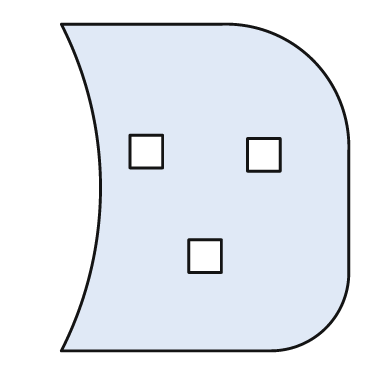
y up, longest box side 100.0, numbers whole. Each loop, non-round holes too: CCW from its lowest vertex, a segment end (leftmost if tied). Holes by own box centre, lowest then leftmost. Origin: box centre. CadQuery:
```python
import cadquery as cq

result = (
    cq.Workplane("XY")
    .moveTo(-44.0, -50.0)
    .lineTo(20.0, -50.0)
    .threePointArc((37.0, -43.0), (44.0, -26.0))
    .lineTo(44.0, 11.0)
    .threePointArc((33.0, 39.0), (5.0, 50.0))
    .lineTo(-44.0, 50.0)
    .threePointArc((-32.0, 0.0), (-44.0, -50.0))
    .close()
    .moveTo(-5.0, -26.0)
    .lineTo(5.0, -26.0)
    .lineTo(5.0, -16.0)
    .lineTo(-5.0, -16.0)
    .close()
    .moveTo(13.0, 5.0)
    .lineTo(23.0, 5.0)
    .lineTo(23.0, 15.0)
    .lineTo(13.0, 15.0)
    .close()
    .moveTo(-23.0, 6.0)
    .lineTo(-13.0, 6.0)
    .lineTo(-13.0, 16.0)
    .lineTo(-23.0, 16.0)
    .close()
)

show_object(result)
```